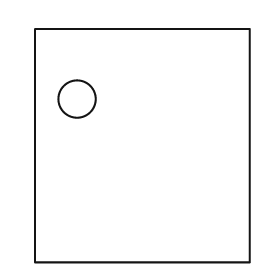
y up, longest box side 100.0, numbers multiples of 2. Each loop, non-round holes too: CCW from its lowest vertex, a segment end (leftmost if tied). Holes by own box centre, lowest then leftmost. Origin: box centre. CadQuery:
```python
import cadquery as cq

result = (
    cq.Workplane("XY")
    .moveTo(-46.0, -50.0)
    .lineTo(46.0, -50.0)
    .lineTo(46.0, 50.0)
    .lineTo(-46.0, 50.0)
    .close()
    .moveTo(-28.0, 20.0)
    .circle(8.0)
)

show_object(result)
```